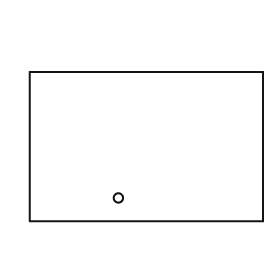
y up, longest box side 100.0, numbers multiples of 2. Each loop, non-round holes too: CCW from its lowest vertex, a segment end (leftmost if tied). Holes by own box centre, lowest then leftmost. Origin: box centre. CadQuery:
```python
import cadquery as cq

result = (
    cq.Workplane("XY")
    .moveTo(-50.0, -32.0)
    .lineTo(50.0, -32.0)
    .lineTo(50.0, 32.0)
    .lineTo(-50.0, 32.0)
    .close()
    .moveTo(-12.0, -22.0)
    .circle(2.0)
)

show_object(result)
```